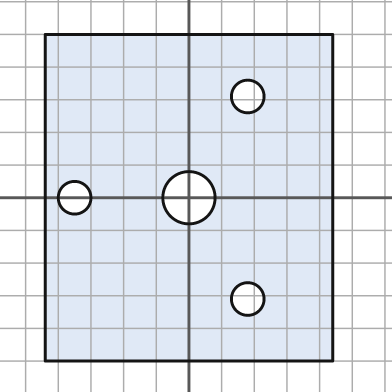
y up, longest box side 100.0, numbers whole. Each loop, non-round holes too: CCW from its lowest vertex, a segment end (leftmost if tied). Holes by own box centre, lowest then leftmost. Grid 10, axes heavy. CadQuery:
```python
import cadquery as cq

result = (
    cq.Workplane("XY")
    .moveTo(-44.0, -50.0)
    .lineTo(44.0, -50.0)
    .lineTo(44.0, 50.0)
    .lineTo(-44.0, 50.0)
    .close()
    .moveTo(18.0, -31.0)
    .circle(5.0)
    .moveTo(-35.0, 0.0)
    .circle(5.0)
    .moveTo(0.0, 0.0)
    .circle(8.0)
    .moveTo(18.0, 31.0)
    .circle(5.0)
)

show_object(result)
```